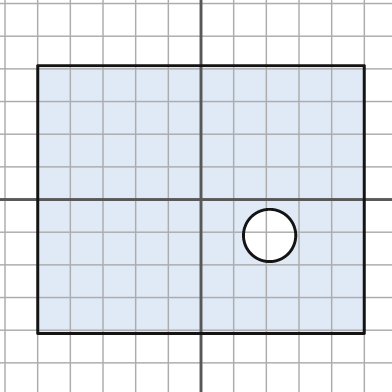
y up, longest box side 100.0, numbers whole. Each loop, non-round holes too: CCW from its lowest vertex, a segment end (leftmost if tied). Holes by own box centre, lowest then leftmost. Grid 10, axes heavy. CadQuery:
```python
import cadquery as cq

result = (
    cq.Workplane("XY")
    .moveTo(-50.0, -41.0)
    .lineTo(50.0, -41.0)
    .lineTo(50.0, 41.0)
    .lineTo(-50.0, 41.0)
    .close()
    .moveTo(21.0, -11.0)
    .circle(8.0)
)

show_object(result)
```